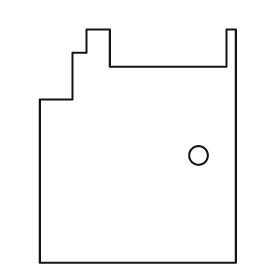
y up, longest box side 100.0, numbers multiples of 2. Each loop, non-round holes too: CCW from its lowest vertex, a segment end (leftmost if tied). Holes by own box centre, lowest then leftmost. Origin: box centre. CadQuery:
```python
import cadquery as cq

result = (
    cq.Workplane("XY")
    .moveTo(-42.0, -50.0)
    .lineTo(42.0, -50.0)
    .lineTo(42.0, 50.0)
    .lineTo(38.0, 50.0)
    .lineTo(38.0, 34.0)
    .lineTo(-12.0, 34.0)
    .lineTo(-12.0, 50.0)
    .lineTo(-22.0, 50.0)
    .lineTo(-22.0, 40.0)
    .lineTo(-28.0, 40.0)
    .lineTo(-28.0, 20.0)
    .lineTo(-42.0, 20.0)
    .close()
    .moveTo(26.0, -4.0)
    .circle(4.0)
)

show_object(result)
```